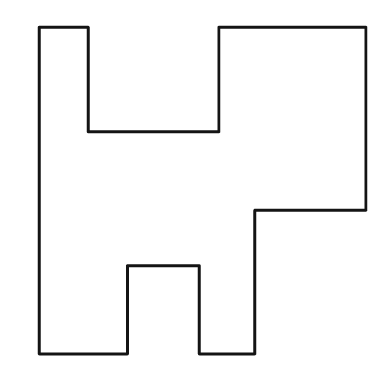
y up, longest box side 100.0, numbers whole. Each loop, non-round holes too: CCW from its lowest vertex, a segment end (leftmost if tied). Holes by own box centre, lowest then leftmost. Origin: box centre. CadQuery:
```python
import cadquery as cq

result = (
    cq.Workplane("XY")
    .moveTo(-50.0, -50.0)
    .lineTo(-23.0, -50.0)
    .lineTo(-23.0, -23.0)
    .lineTo(-1.0, -23.0)
    .lineTo(-1.0, -50.0)
    .lineTo(16.0, -50.0)
    .lineTo(16.0, -6.0)
    .lineTo(50.0, -6.0)
    .lineTo(50.0, 50.0)
    .lineTo(5.0, 50.0)
    .lineTo(5.0, 18.0)
    .lineTo(-35.0, 18.0)
    .lineTo(-35.0, 50.0)
    .lineTo(-50.0, 50.0)
    .close()
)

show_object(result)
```